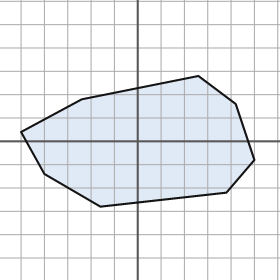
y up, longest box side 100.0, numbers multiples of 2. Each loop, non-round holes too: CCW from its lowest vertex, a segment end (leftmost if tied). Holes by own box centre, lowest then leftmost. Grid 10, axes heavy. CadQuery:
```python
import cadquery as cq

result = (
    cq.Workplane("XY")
    .moveTo(-16.0, -28.0)
    .lineTo(38.0, -22.0)
    .lineTo(50.0, -8.0)
    .lineTo(42.0, 16.0)
    .lineTo(26.0, 28.0)
    .lineTo(-24.0, 18.0)
    .lineTo(-50.0, 4.0)
    .lineTo(-40.0, -14.0)
    .close()
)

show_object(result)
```